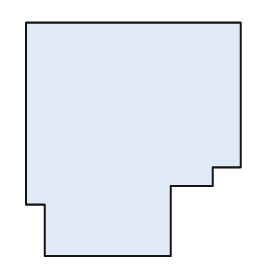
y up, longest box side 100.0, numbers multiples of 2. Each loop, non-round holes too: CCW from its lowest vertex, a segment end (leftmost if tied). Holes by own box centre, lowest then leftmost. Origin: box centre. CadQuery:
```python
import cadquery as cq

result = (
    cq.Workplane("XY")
    .moveTo(-38.0, -50.0)
    .lineTo(16.0, -50.0)
    .lineTo(16.0, -20.0)
    .lineTo(34.0, -20.0)
    .lineTo(34.0, -12.0)
    .lineTo(46.0, -12.0)
    .lineTo(46.0, 50.0)
    .lineTo(-46.0, 50.0)
    .lineTo(-46.0, -28.0)
    .lineTo(-38.0, -28.0)
    .close()
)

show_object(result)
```